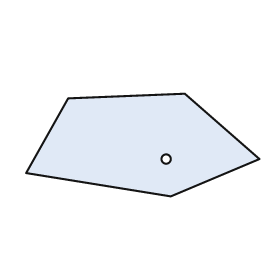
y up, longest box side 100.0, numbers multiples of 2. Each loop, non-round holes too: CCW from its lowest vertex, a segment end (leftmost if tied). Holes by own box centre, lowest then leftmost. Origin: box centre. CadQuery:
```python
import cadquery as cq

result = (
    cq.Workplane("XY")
    .moveTo(12.0, -22.0)
    .lineTo(50.0, -6.0)
    .lineTo(18.0, 22.0)
    .lineTo(-32.0, 20.0)
    .lineTo(-50.0, -12.0)
    .close()
    .moveTo(10.0, -6.0)
    .circle(2.0)
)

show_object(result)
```